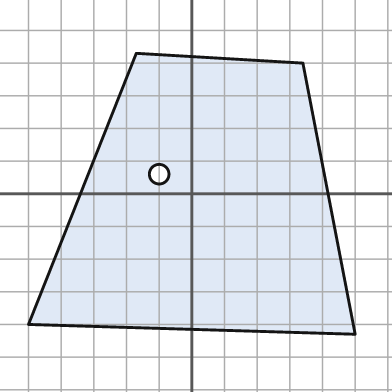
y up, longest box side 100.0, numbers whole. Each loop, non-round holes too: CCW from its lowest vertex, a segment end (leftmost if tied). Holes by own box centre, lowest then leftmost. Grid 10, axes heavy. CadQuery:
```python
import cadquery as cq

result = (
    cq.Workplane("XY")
    .moveTo(50.0, -43.0)
    .lineTo(34.0, 40.0)
    .lineTo(-17.0, 43.0)
    .lineTo(-50.0, -40.0)
    .close()
    .moveTo(-10.0, 6.0)
    .circle(3.0)
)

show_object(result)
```